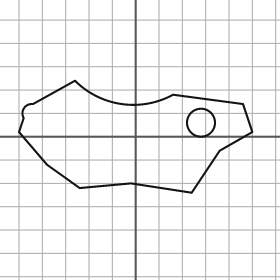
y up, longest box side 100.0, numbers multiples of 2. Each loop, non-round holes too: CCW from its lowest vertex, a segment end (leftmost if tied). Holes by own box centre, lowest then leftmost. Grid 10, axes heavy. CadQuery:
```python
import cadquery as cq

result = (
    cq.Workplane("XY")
    .moveTo(24.0, -24.0)
    .lineTo(36.0, -6.0)
    .lineTo(50.0, 2.0)
    .lineTo(46.0, 14.0)
    .lineTo(16.0, 18.0)
    .threePointArc((-6.0, 14.0), (-26.0, 24.0))
    .lineTo(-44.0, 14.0)
    .threePointArc((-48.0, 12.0), (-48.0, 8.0))
    .lineTo(-50.0, 2.0)
    .lineTo(-38.0, -12.0)
    .lineTo(-24.0, -22.0)
    .lineTo(-2.0, -20.0)
    .close()
    .moveTo(28.0, 6.0)
    .circle(6.0)
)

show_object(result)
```